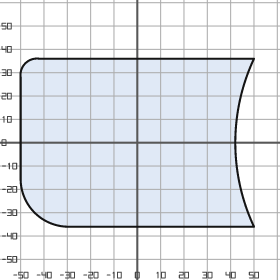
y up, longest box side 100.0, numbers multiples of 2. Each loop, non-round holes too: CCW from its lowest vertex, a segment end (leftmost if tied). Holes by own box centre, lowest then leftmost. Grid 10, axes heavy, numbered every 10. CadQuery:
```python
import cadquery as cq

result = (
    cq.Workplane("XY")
    .moveTo(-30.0, -36.0)
    .lineTo(50.0, -36.0)
    .threePointArc((42.0, 0.0), (50.0, 36.0))
    .lineTo(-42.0, 36.0)
    .threePointArc((-48.0, 34.0), (-50.0, 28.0))
    .lineTo(-50.0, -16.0)
    .threePointArc((-44.0, -30.0), (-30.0, -36.0))
    .close()
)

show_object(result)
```